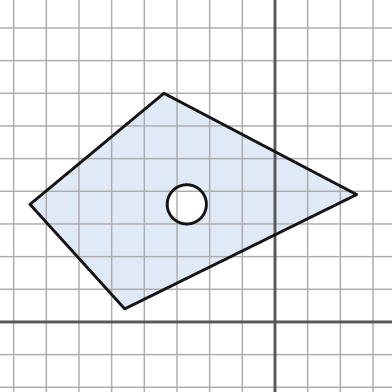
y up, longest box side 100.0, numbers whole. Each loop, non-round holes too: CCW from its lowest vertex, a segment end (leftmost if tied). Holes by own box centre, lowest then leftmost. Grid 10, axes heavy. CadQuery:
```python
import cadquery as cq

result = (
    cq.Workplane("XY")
    .moveTo(-46.0, 4.0)
    .lineTo(25.0, 39.0)
    .lineTo(-34.0, 70.0)
    .lineTo(-75.0, 36.0)
    .close()
    .moveTo(-27.0, 36.0)
    .circle(6.0)
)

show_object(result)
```